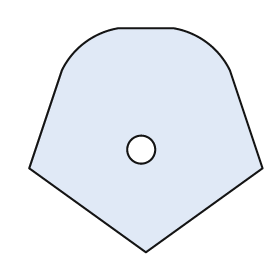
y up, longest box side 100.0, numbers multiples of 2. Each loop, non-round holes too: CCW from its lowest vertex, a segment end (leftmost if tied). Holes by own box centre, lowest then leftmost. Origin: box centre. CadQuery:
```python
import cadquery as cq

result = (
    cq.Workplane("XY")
    .moveTo(0.0, -48.0)
    .lineTo(50.0, -12.0)
    .lineTo(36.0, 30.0)
    .threePointArc((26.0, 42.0), (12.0, 48.0))
    .lineTo(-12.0, 48.0)
    .threePointArc((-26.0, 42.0), (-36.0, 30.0))
    .lineTo(-50.0, -12.0)
    .close()
    .moveTo(-2.0, -4.0)
    .circle(6.0)
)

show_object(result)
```